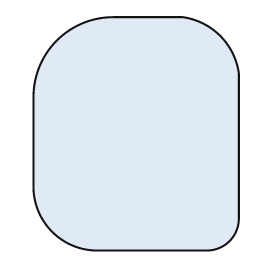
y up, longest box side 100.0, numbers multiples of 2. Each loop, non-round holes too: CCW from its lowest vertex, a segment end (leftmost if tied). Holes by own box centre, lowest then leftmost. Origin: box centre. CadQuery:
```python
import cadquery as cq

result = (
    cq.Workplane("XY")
    .moveTo(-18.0, -50.0)
    .lineTo(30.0, -50.0)
    .threePointArc((40.0, -46.0), (44.0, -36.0))
    .lineTo(44.0, 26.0)
    .threePointArc((36.0, 42.0), (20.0, 50.0))
    .lineTo(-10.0, 50.0)
    .threePointArc((-34.0, 40.0), (-44.0, 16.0))
    .lineTo(-44.0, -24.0)
    .threePointArc((-36.0, -42.0), (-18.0, -50.0))
    .close()
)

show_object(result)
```